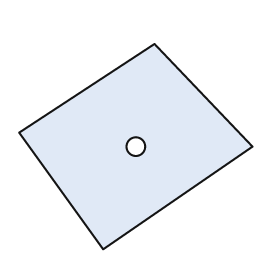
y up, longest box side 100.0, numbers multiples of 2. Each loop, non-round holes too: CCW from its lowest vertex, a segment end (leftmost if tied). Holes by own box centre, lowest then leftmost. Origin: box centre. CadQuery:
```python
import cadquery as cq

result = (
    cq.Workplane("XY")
    .moveTo(-14.0, -44.0)
    .lineTo(50.0, 0.0)
    .lineTo(8.0, 44.0)
    .lineTo(-50.0, 6.0)
    .close()
    .moveTo(0.0, 0.0)
    .circle(4.0)
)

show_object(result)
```